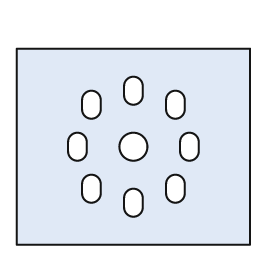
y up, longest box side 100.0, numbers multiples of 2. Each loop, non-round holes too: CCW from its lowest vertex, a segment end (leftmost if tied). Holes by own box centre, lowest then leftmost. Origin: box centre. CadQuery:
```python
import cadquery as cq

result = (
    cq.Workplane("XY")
    .moveTo(-50.0, -42.0)
    .lineTo(50.0, -42.0)
    .lineTo(50.0, 42.0)
    .lineTo(-50.0, 42.0)
    .close()
    .moveTo(-4.0, -26.0)
    .threePointArc((0.0, -30.0), (4.0, -26.0))
    .lineTo(4.0, -22.0)
    .threePointArc((0.0, -18.0), (-4.0, -22.0))
    .close()
    .moveTo(-22.0, -20.0)
    .threePointArc((-18.0, -24.0), (-14.0, -20.0))
    .lineTo(-14.0, -16.0)
    .threePointArc((-18.0, -12.0), (-22.0, -16.0))
    .close()
    .moveTo(14.0, -20.0)
    .threePointArc((18.0, -24.0), (22.0, -20.0))
    .lineTo(22.0, -16.0)
    .threePointArc((18.0, -12.0), (14.0, -16.0))
    .close()
    .moveTo(-28.0, -2.0)
    .threePointArc((-24.0, -6.0), (-20.0, -2.0))
    .lineTo(-20.0, 2.0)
    .threePointArc((-24.0, 6.0), (-28.0, 2.0))
    .close()
    .moveTo(0.0, 0.0)
    .circle(6.0)
    .moveTo(20.0, -2.0)
    .threePointArc((24.0, -6.0), (28.0, -2.0))
    .lineTo(28.0, 2.0)
    .threePointArc((24.0, 6.0), (20.0, 2.0))
    .close()
    .moveTo(-22.0, 16.0)
    .threePointArc((-18.0, 12.0), (-14.0, 16.0))
    .lineTo(-14.0, 20.0)
    .threePointArc((-18.0, 24.0), (-22.0, 20.0))
    .close()
    .moveTo(14.0, 16.0)
    .threePointArc((18.0, 12.0), (22.0, 16.0))
    .lineTo(22.0, 20.0)
    .threePointArc((18.0, 24.0), (14.0, 20.0))
    .close()
    .moveTo(-4.0, 22.0)
    .threePointArc((0.0, 18.0), (4.0, 22.0))
    .lineTo(4.0, 26.0)
    .threePointArc((0.0, 30.0), (-4.0, 26.0))
    .close()
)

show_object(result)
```